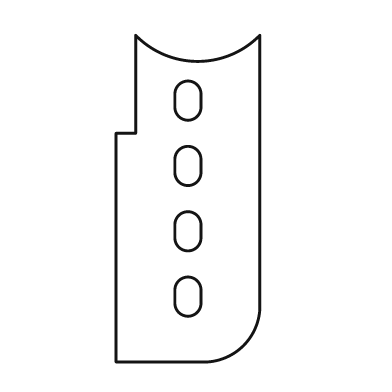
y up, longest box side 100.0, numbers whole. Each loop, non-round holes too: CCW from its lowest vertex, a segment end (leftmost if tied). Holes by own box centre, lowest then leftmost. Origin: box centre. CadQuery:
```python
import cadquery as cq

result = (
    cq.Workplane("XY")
    .moveTo(-22.0, -50.0)
    .lineTo(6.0, -50.0)
    .threePointArc((17.0, -45.0), (22.0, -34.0))
    .lineTo(22.0, 50.0)
    .threePointArc((3.0, 42.0), (-16.0, 50.0))
    .lineTo(-16.0, 20.0)
    .lineTo(-22.0, 20.0)
    .close()
    .moveTo(-4.0, -32.0)
    .threePointArc((0.0, -36.0), (4.0, -32.0))
    .lineTo(4.0, -28.0)
    .threePointArc((0.0, -24.0), (-4.0, -28.0))
    .close()
    .moveTo(-4.0, -12.0)
    .threePointArc((0.0, -16.0), (4.0, -12.0))
    .lineTo(4.0, -8.0)
    .threePointArc((0.0, -4.0), (-4.0, -8.0))
    .close()
    .moveTo(-4.0, 8.0)
    .threePointArc((0.0, 4.0), (4.0, 8.0))
    .lineTo(4.0, 12.0)
    .threePointArc((0.0, 16.0), (-4.0, 12.0))
    .close()
    .moveTo(-4.0, 28.0)
    .threePointArc((0.0, 24.0), (4.0, 28.0))
    .lineTo(4.0, 32.0)
    .threePointArc((0.0, 36.0), (-4.0, 32.0))
    .close()
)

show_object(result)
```